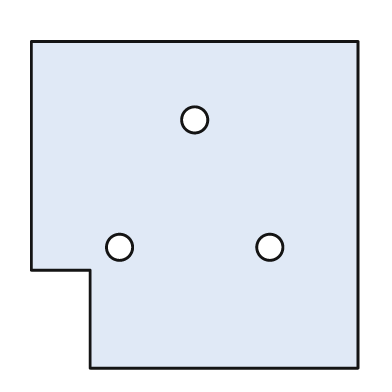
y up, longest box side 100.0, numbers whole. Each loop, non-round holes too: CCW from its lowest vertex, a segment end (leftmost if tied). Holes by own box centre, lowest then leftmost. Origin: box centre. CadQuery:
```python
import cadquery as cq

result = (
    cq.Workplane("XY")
    .moveTo(-32.0, -50.0)
    .lineTo(50.0, -50.0)
    .lineTo(50.0, 50.0)
    .lineTo(-50.0, 50.0)
    .lineTo(-50.0, -20.0)
    .lineTo(-32.0, -20.0)
    .close()
    .moveTo(-23.0, -13.0)
    .circle(4.0)
    .moveTo(23.0, -13.0)
    .circle(4.0)
    .moveTo(0.0, 26.0)
    .circle(4.0)
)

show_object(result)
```